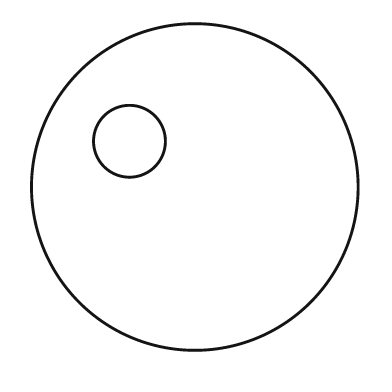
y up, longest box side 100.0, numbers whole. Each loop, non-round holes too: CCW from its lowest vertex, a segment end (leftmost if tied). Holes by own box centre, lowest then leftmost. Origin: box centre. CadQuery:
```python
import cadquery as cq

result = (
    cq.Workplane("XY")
    .moveTo(0.0, 0.0)
    .circle(50.0)
    .moveTo(-20.0, 14.0)
    .circle(11.0)
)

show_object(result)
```